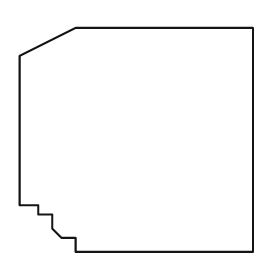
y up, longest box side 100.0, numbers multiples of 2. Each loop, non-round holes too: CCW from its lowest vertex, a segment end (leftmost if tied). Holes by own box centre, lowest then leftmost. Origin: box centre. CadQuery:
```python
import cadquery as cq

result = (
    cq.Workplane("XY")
    .moveTo(-26.0, -48.0)
    .lineTo(50.0, -48.0)
    .lineTo(50.0, 48.0)
    .lineTo(-26.0, 48.0)
    .lineTo(-50.0, 36.0)
    .lineTo(-50.0, -28.0)
    .lineTo(-42.0, -28.0)
    .lineTo(-42.0, -32.0)
    .lineTo(-36.0, -32.0)
    .lineTo(-36.0, -38.0)
    .lineTo(-32.0, -42.0)
    .lineTo(-26.0, -42.0)
    .close()
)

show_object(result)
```